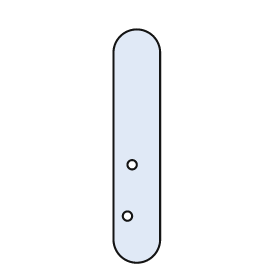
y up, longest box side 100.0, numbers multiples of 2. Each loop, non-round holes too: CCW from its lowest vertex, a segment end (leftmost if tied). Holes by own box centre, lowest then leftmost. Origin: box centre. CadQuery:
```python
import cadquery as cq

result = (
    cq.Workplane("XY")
    .moveTo(-10.0, -40.0)
    .threePointArc((0.0, -50.0), (10.0, -40.0))
    .lineTo(10.0, 40.0)
    .threePointArc((0.0, 50.0), (-10.0, 40.0))
    .close()
    .moveTo(-4.0, -30.0)
    .circle(2.0)
    .moveTo(-2.0, -8.0)
    .circle(2.0)
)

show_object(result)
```